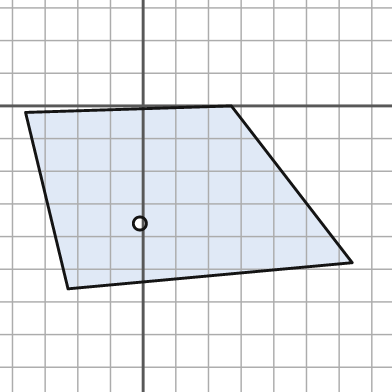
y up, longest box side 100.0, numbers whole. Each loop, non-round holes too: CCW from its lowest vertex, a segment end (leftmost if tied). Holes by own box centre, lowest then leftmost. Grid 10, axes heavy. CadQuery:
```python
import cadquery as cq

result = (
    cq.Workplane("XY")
    .moveTo(-23.0, -56.0)
    .lineTo(64.0, -48.0)
    .lineTo(27.0, 0.0)
    .lineTo(-36.0, -2.0)
    .close()
    .moveTo(-1.0, -36.0)
    .circle(2.0)
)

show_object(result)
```